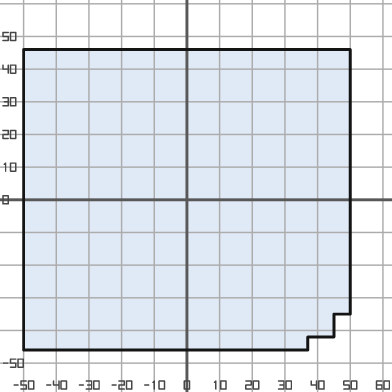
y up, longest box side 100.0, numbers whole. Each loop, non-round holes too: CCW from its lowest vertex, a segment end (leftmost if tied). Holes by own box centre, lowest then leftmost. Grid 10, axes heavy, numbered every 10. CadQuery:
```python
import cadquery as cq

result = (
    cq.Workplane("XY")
    .moveTo(-50.0, -46.0)
    .lineTo(37.0, -46.0)
    .lineTo(37.0, -42.0)
    .lineTo(45.0, -42.0)
    .lineTo(45.0, -35.0)
    .lineTo(50.0, -35.0)
    .lineTo(50.0, 46.0)
    .lineTo(-50.0, 46.0)
    .close()
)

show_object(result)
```